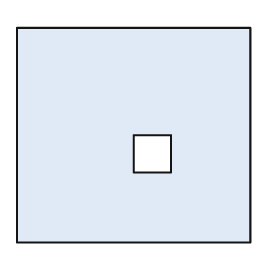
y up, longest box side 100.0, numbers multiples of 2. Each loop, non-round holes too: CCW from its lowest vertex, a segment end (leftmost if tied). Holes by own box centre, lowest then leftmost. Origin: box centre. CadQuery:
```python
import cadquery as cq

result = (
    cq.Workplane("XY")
    .moveTo(-50.0, -46.0)
    .lineTo(50.0, -46.0)
    .lineTo(50.0, 46.0)
    .lineTo(-50.0, 46.0)
    .close()
    .moveTo(0.0, -16.0)
    .lineTo(16.0, -16.0)
    .lineTo(16.0, 0.0)
    .lineTo(0.0, 0.0)
    .close()
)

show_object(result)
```